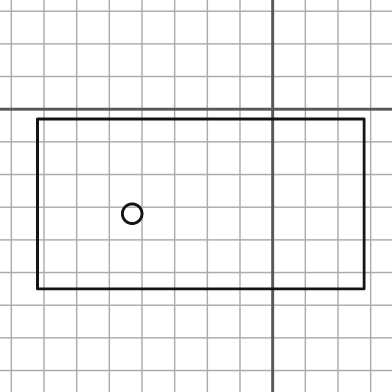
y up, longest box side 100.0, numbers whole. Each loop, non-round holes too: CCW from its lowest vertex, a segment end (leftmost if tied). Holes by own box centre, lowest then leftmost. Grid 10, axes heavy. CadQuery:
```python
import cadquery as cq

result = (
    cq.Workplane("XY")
    .moveTo(-72.0, -55.0)
    .lineTo(28.0, -55.0)
    .lineTo(28.0, -3.0)
    .lineTo(-72.0, -3.0)
    .close()
    .moveTo(-43.0, -32.0)
    .circle(3.0)
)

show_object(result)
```